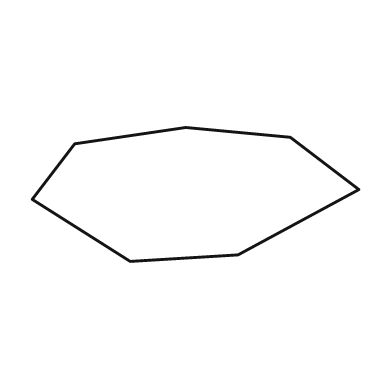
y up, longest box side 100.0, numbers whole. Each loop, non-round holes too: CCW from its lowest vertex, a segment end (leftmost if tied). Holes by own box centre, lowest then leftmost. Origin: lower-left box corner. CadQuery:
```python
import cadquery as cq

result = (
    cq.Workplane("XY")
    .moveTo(30.0, 0.0)
    .lineTo(63.0, 2.0)
    .lineTo(100.0, 22.0)
    .lineTo(79.0, 38.0)
    .lineTo(47.0, 41.0)
    .lineTo(13.0, 36.0)
    .lineTo(0.0, 19.0)
    .close()
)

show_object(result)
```